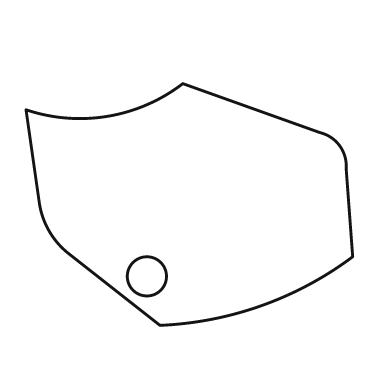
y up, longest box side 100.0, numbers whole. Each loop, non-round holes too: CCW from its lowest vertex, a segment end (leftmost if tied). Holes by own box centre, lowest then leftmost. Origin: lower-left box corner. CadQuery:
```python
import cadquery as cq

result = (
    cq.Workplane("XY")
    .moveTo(41.0, 0.0)
    .threePointArc((72.0, 6.0), (100.0, 21.0))
    .lineTo(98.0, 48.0)
    .threePointArc((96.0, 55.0), (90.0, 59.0))
    .lineTo(48.0, 74.0)
    .threePointArc((25.0, 64.0), (0.0, 66.0))
    .lineTo(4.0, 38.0)
    .threePointArc((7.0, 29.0), (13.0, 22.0))
    .close()
    .moveTo(37.0, 15.0)
    .circle(6.0)
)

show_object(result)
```